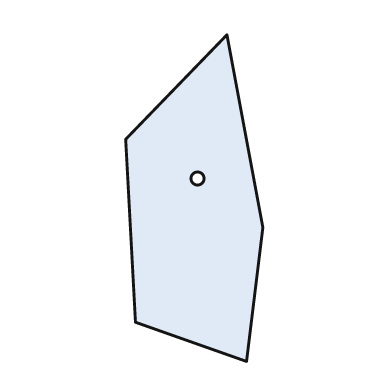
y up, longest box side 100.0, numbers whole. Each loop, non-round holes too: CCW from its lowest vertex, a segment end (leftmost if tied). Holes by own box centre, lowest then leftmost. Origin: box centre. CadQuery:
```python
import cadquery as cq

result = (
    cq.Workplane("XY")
    .moveTo(16.0, -50.0)
    .lineTo(21.0, -9.0)
    .lineTo(10.0, 50.0)
    .lineTo(-21.0, 18.0)
    .lineTo(-18.0, -38.0)
    .close()
    .moveTo(1.0, 6.0)
    .circle(2.0)
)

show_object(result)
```